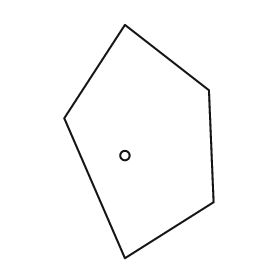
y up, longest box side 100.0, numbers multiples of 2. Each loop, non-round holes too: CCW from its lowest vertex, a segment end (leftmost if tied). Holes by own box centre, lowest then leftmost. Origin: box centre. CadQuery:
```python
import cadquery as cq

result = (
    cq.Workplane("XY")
    .moveTo(-6.0, -50.0)
    .lineTo(32.0, -26.0)
    .lineTo(30.0, 22.0)
    .lineTo(-6.0, 50.0)
    .lineTo(-32.0, 10.0)
    .close()
    .moveTo(-6.0, -6.0)
    .circle(2.0)
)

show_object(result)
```